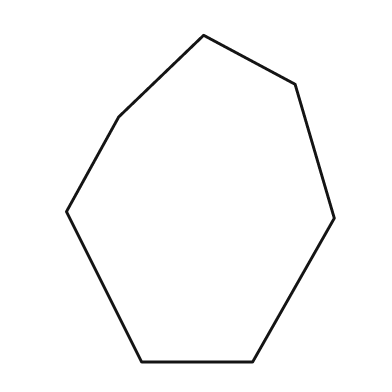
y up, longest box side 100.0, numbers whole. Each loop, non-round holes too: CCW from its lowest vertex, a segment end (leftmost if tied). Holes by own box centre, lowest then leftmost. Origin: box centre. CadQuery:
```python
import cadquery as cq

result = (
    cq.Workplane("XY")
    .moveTo(-18.0, -50.0)
    .lineTo(16.0, -50.0)
    .lineTo(41.0, -6.0)
    .lineTo(29.0, 35.0)
    .lineTo(1.0, 50.0)
    .lineTo(-25.0, 25.0)
    .lineTo(-41.0, -4.0)
    .close()
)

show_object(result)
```